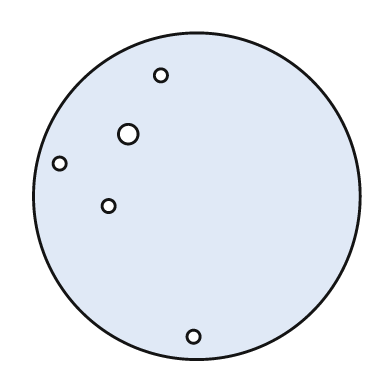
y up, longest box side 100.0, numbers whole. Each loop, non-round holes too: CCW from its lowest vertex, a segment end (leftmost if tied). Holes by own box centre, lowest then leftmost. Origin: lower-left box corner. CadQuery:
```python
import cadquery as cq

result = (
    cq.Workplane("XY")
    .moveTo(50.0, 50.0)
    .circle(50.0)
    .moveTo(49.0, 7.0)
    .circle(2.0)
    .moveTo(23.0, 47.0)
    .circle(2.0)
    .moveTo(8.0, 60.0)
    .circle(2.0)
    .moveTo(29.0, 69.0)
    .circle(3.0)
    .moveTo(39.0, 87.0)
    .circle(2.0)
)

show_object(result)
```